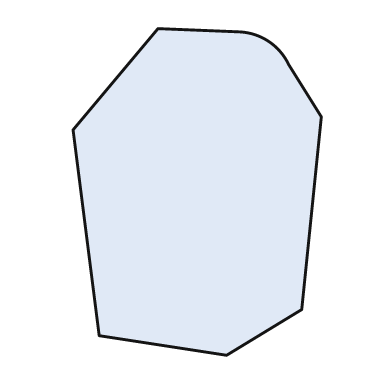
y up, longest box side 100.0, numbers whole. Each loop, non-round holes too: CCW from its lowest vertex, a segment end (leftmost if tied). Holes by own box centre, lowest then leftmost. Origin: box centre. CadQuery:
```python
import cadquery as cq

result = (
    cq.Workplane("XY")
    .moveTo(9.0, -50.0)
    .lineTo(32.0, -36.0)
    .lineTo(38.0, 23.0)
    .lineTo(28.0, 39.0)
    .threePointArc((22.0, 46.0), (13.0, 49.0))
    .lineTo(-12.0, 50.0)
    .lineTo(-38.0, 19.0)
    .lineTo(-30.0, -44.0)
    .close()
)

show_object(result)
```